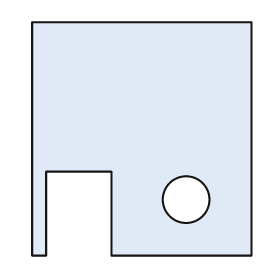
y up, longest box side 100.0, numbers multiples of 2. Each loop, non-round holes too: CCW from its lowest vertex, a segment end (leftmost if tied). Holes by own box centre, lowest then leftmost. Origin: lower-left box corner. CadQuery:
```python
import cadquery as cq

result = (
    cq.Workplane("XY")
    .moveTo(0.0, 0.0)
    .lineTo(6.0, 0.0)
    .lineTo(6.0, 36.0)
    .lineTo(34.0, 36.0)
    .lineTo(34.0, 0.0)
    .lineTo(94.0, 0.0)
    .lineTo(94.0, 100.0)
    .lineTo(0.0, 100.0)
    .close()
    .moveTo(66.0, 24.0)
    .circle(10.0)
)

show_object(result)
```